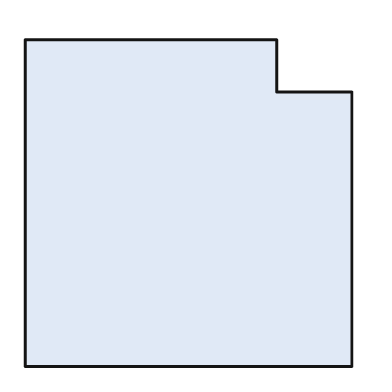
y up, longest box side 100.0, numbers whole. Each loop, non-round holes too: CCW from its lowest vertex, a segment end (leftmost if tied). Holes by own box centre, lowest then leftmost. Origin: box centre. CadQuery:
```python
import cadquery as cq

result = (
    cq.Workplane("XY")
    .moveTo(-50.0, -50.0)
    .lineTo(50.0, -50.0)
    .lineTo(50.0, 34.0)
    .lineTo(27.0, 34.0)
    .lineTo(27.0, 50.0)
    .lineTo(-50.0, 50.0)
    .close()
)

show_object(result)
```